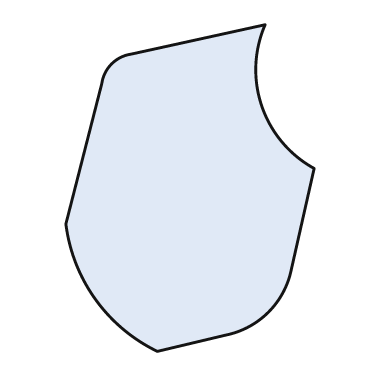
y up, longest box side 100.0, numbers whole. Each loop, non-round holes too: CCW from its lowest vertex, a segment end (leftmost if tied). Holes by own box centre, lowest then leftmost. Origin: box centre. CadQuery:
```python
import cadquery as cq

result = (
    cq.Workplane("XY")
    .moveTo(-10.0, -50.0)
    .lineTo(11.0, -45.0)
    .threePointArc((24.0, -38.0), (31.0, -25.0))
    .lineTo(38.0, 6.0)
    .threePointArc((22.0, 25.0), (23.0, 50.0))
    .lineTo(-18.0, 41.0)
    .threePointArc((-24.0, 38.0), (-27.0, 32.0))
    .lineTo(-38.0, -11.0)
    .threePointArc((-29.0, -34.0), (-10.0, -50.0))
    .close()
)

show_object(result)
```